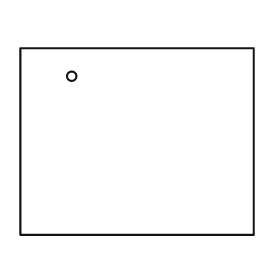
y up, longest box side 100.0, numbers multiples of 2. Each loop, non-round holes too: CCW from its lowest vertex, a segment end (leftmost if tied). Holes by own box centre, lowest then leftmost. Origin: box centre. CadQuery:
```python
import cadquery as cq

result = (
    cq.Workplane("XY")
    .moveTo(-50.0, -40.0)
    .lineTo(50.0, -40.0)
    .lineTo(50.0, 40.0)
    .lineTo(-50.0, 40.0)
    .close()
    .moveTo(-28.0, 28.0)
    .circle(2.0)
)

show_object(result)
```